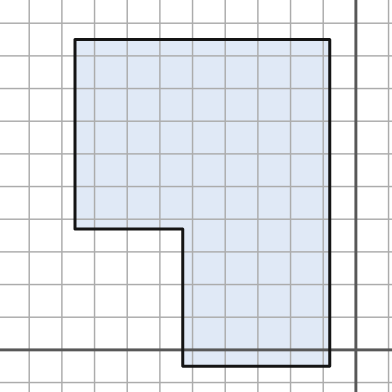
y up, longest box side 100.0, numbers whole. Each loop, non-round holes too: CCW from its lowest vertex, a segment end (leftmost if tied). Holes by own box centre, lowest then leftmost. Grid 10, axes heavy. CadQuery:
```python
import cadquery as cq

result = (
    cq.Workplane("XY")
    .moveTo(-53.0, -5.0)
    .lineTo(-8.0, -5.0)
    .lineTo(-8.0, 95.0)
    .lineTo(-86.0, 95.0)
    .lineTo(-86.0, 37.0)
    .lineTo(-53.0, 37.0)
    .close()
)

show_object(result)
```